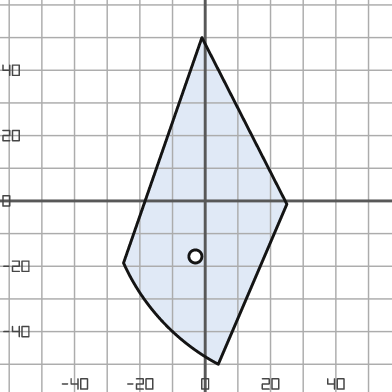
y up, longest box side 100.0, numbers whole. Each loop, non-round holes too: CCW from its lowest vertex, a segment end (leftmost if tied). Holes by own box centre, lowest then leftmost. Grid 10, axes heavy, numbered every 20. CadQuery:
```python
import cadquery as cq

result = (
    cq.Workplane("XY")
    .moveTo(4.0, -50.0)
    .lineTo(25.0, -1.0)
    .lineTo(-1.0, 50.0)
    .lineTo(-25.0, -19.0)
    .threePointArc((-13.0, -37.0), (4.0, -50.0))
    .close()
    .moveTo(-3.0, -17.0)
    .circle(2.0)
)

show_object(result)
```